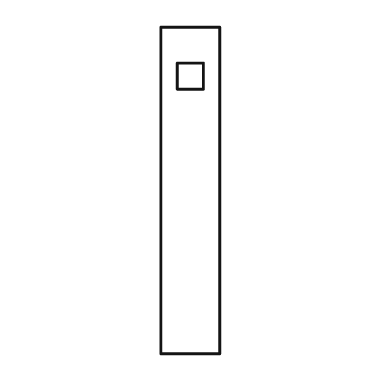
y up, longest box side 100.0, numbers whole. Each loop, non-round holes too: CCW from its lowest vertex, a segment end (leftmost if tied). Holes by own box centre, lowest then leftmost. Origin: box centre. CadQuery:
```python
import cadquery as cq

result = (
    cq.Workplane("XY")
    .moveTo(-9.0, -50.0)
    .lineTo(9.0, -50.0)
    .lineTo(9.0, 50.0)
    .lineTo(-9.0, 50.0)
    .close()
    .moveTo(-4.0, 31.0)
    .lineTo(4.0, 31.0)
    .lineTo(4.0, 39.0)
    .lineTo(-4.0, 39.0)
    .close()
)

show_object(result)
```